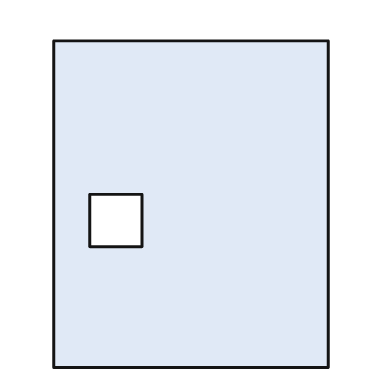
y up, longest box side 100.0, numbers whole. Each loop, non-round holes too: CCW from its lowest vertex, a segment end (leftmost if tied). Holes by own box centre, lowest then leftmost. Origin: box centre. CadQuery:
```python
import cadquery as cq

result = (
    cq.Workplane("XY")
    .moveTo(-42.0, -50.0)
    .lineTo(42.0, -50.0)
    .lineTo(42.0, 50.0)
    .lineTo(-42.0, 50.0)
    .close()
    .moveTo(-31.0, -13.0)
    .lineTo(-15.0, -13.0)
    .lineTo(-15.0, 3.0)
    .lineTo(-31.0, 3.0)
    .close()
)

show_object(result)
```